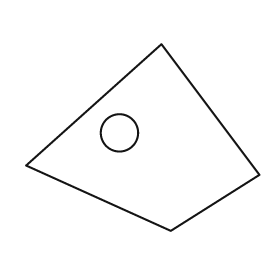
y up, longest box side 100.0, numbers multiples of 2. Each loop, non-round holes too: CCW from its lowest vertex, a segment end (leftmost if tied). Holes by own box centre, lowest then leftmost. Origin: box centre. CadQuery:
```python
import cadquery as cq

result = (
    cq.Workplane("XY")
    .moveTo(12.0, -40.0)
    .lineTo(50.0, -16.0)
    .lineTo(8.0, 40.0)
    .lineTo(-50.0, -12.0)
    .close()
    .moveTo(-10.0, 2.0)
    .circle(8.0)
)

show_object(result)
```